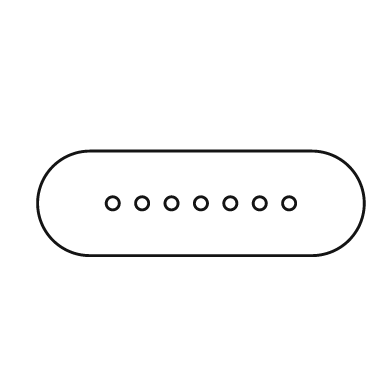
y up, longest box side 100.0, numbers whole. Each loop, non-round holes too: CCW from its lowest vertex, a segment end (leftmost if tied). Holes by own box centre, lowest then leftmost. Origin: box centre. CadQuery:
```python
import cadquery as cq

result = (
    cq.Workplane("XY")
    .moveTo(-34.0, -16.0)
    .lineTo(34.0, -16.0)
    .threePointArc((50.0, 0.0), (34.0, 16.0))
    .lineTo(-34.0, 16.0)
    .threePointArc((-50.0, 0.0), (-34.0, -16.0))
    .close()
    .moveTo(-27.0, 0.0)
    .circle(2.0)
    .moveTo(-18.0, 0.0)
    .circle(2.0)
    .moveTo(-9.0, 0.0)
    .circle(2.0)
    .moveTo(0.0, 0.0)
    .circle(2.0)
    .moveTo(9.0, 0.0)
    .circle(2.0)
    .moveTo(18.0, 0.0)
    .circle(2.0)
    .moveTo(27.0, 0.0)
    .circle(2.0)
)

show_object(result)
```